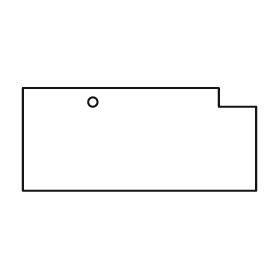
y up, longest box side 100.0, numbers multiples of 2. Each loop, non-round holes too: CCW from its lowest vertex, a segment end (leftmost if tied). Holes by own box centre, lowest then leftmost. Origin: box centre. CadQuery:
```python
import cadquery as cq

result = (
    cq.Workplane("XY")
    .moveTo(-50.0, -22.0)
    .lineTo(50.0, -22.0)
    .lineTo(50.0, 14.0)
    .lineTo(34.0, 14.0)
    .lineTo(34.0, 22.0)
    .lineTo(-50.0, 22.0)
    .close()
    .moveTo(-20.0, 16.0)
    .circle(2.0)
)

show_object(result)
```